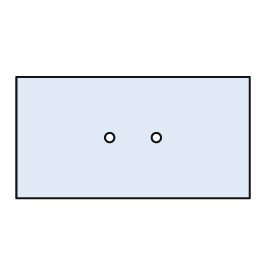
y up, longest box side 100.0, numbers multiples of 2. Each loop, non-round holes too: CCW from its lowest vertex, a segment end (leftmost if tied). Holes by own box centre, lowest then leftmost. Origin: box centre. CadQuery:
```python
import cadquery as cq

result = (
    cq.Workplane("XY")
    .moveTo(-50.0, -26.0)
    .lineTo(50.0, -26.0)
    .lineTo(50.0, 26.0)
    .lineTo(-50.0, 26.0)
    .close()
    .moveTo(-10.0, 0.0)
    .circle(2.0)
    .moveTo(10.0, 0.0)
    .circle(2.0)
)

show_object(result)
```